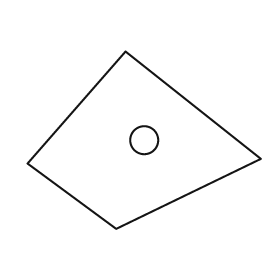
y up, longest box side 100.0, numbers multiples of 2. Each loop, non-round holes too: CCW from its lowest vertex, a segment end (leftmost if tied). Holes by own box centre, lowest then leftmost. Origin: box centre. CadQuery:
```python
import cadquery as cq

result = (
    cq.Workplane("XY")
    .moveTo(-12.0, -38.0)
    .lineTo(50.0, -8.0)
    .lineTo(-8.0, 38.0)
    .lineTo(-50.0, -10.0)
    .close()
    .moveTo(0.0, 0.0)
    .circle(6.0)
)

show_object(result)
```